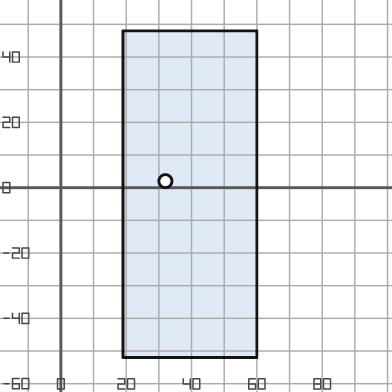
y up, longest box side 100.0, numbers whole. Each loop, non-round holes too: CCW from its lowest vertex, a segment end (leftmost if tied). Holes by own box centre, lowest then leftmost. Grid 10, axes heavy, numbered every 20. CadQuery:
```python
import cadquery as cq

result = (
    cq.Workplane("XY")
    .moveTo(19.0, -52.0)
    .lineTo(60.0, -52.0)
    .lineTo(60.0, 48.0)
    .lineTo(19.0, 48.0)
    .close()
    .moveTo(32.0, 2.0)
    .circle(2.0)
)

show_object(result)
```